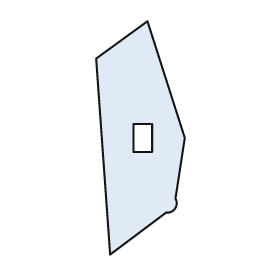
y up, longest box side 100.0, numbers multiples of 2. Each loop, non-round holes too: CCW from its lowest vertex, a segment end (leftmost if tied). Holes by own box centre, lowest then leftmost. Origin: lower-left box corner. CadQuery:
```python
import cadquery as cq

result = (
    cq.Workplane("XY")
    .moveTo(6.0, 0.0)
    .lineTo(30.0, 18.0)
    .threePointArc((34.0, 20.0), (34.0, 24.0))
    .lineTo(38.0, 50.0)
    .lineTo(22.0, 100.0)
    .lineTo(0.0, 84.0)
    .close()
    .moveTo(16.0, 44.0)
    .lineTo(24.0, 44.0)
    .lineTo(24.0, 56.0)
    .lineTo(16.0, 56.0)
    .close()
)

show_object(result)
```